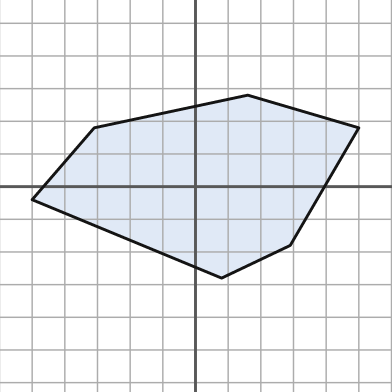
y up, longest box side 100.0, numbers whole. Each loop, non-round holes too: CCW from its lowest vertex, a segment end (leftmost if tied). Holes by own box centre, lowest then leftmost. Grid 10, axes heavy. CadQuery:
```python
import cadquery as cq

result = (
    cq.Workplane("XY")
    .moveTo(8.0, -28.0)
    .lineTo(29.0, -18.0)
    .lineTo(50.0, 18.0)
    .lineTo(16.0, 28.0)
    .lineTo(-31.0, 18.0)
    .lineTo(-50.0, -4.0)
    .close()
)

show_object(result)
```